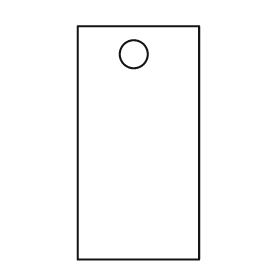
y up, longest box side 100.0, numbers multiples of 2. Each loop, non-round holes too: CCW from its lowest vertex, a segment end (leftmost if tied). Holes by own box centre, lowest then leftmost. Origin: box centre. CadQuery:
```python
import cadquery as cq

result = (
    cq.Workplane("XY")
    .moveTo(-26.0, -50.0)
    .lineTo(26.0, -50.0)
    .lineTo(26.0, 50.0)
    .lineTo(-26.0, 50.0)
    .close()
    .moveTo(-2.0, 38.0)
    .circle(6.0)
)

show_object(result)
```